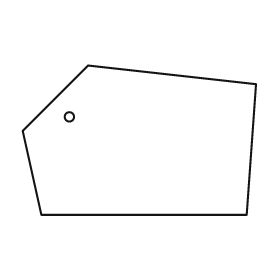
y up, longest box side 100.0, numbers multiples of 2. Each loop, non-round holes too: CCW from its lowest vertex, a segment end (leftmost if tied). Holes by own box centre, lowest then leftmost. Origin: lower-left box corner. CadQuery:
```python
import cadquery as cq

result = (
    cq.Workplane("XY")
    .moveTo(8.0, 0.0)
    .lineTo(96.0, 0.0)
    .lineTo(100.0, 56.0)
    .lineTo(28.0, 64.0)
    .lineTo(0.0, 36.0)
    .close()
    .moveTo(20.0, 42.0)
    .circle(2.0)
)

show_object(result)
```